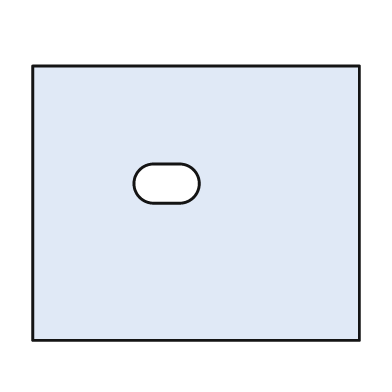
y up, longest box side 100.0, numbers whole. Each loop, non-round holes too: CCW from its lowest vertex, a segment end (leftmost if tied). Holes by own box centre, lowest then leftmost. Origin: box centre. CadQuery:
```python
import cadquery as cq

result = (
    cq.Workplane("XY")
    .moveTo(-50.0, -42.0)
    .lineTo(50.0, -42.0)
    .lineTo(50.0, 42.0)
    .lineTo(-50.0, 42.0)
    .close()
    .moveTo(-13.0, 0.0)
    .lineTo(-5.0, 0.0)
    .threePointArc((1.0, 6.0), (-5.0, 12.0))
    .lineTo(-13.0, 12.0)
    .threePointArc((-19.0, 6.0), (-13.0, 0.0))
    .close()
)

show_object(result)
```